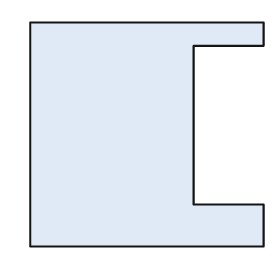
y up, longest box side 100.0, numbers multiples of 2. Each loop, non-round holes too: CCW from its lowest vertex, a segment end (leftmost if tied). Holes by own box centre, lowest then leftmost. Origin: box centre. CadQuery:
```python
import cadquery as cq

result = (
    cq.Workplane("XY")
    .moveTo(-50.0, -48.0)
    .lineTo(50.0, -48.0)
    .lineTo(50.0, -30.0)
    .lineTo(20.0, -30.0)
    .lineTo(20.0, 38.0)
    .lineTo(50.0, 38.0)
    .lineTo(50.0, 48.0)
    .lineTo(-50.0, 48.0)
    .close()
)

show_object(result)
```